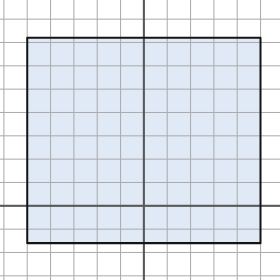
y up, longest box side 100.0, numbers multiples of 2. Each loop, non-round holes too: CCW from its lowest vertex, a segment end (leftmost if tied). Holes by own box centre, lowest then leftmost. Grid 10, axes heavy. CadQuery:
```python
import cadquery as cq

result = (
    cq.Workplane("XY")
    .moveTo(-50.0, -16.0)
    .lineTo(50.0, -16.0)
    .lineTo(50.0, 72.0)
    .lineTo(-50.0, 72.0)
    .close()
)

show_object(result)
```